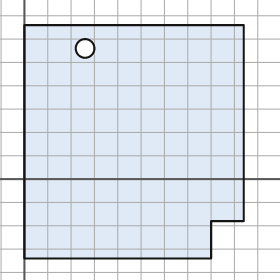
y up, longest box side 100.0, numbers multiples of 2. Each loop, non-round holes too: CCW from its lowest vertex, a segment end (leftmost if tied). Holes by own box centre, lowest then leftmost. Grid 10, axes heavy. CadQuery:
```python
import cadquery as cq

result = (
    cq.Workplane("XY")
    .moveTo(0.0, -34.0)
    .lineTo(80.0, -34.0)
    .lineTo(80.0, -18.0)
    .lineTo(94.0, -18.0)
    .lineTo(94.0, 66.0)
    .lineTo(0.0, 66.0)
    .close()
    .moveTo(26.0, 56.0)
    .circle(4.0)
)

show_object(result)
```